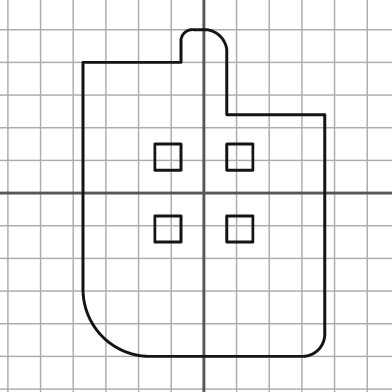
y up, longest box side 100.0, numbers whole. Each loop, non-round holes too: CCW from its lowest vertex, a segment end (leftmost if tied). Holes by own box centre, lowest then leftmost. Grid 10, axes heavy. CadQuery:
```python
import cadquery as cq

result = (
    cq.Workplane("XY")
    .moveTo(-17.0, -50.0)
    .lineTo(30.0, -50.0)
    .threePointArc((35.0, -48.0), (37.0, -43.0))
    .lineTo(37.0, 24.0)
    .lineTo(7.0, 24.0)
    .lineTo(7.0, 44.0)
    .threePointArc((5.0, 48.0), (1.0, 50.0))
    .lineTo(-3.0, 50.0)
    .threePointArc((-6.0, 49.0), (-7.0, 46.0))
    .lineTo(-7.0, 40.0)
    .lineTo(-37.0, 40.0)
    .lineTo(-37.0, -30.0)
    .threePointArc((-31.0, -44.0), (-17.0, -50.0))
    .close()
    .moveTo(-15.0, -15.0)
    .lineTo(-7.0, -15.0)
    .lineTo(-7.0, -7.0)
    .lineTo(-15.0, -7.0)
    .close()
    .moveTo(7.0, -15.0)
    .lineTo(15.0, -15.0)
    .lineTo(15.0, -7.0)
    .lineTo(7.0, -7.0)
    .close()
    .moveTo(-15.0, 7.0)
    .lineTo(-7.0, 7.0)
    .lineTo(-7.0, 15.0)
    .lineTo(-15.0, 15.0)
    .close()
    .moveTo(7.0, 7.0)
    .lineTo(15.0, 7.0)
    .lineTo(15.0, 15.0)
    .lineTo(7.0, 15.0)
    .close()
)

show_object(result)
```